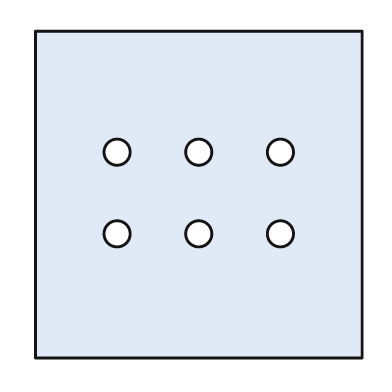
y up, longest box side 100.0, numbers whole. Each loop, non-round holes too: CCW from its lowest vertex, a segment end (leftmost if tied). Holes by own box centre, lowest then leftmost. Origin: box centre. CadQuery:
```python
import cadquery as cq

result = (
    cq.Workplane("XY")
    .moveTo(-50.0, -50.0)
    .lineTo(50.0, -50.0)
    .lineTo(50.0, 50.0)
    .lineTo(-50.0, 50.0)
    .close()
    .moveTo(-25.0, -12.0)
    .circle(4.0)
    .moveTo(0.0, -12.0)
    .circle(4.0)
    .moveTo(25.0, -12.0)
    .circle(4.0)
    .moveTo(-25.0, 13.0)
    .circle(4.0)
    .moveTo(0.0, 13.0)
    .circle(4.0)
    .moveTo(25.0, 13.0)
    .circle(4.0)
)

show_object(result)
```